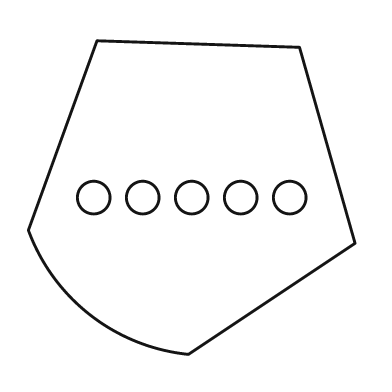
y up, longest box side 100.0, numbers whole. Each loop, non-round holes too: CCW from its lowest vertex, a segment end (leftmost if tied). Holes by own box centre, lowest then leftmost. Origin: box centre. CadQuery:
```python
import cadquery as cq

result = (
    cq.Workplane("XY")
    .moveTo(-1.0, -48.0)
    .lineTo(50.0, -14.0)
    .lineTo(33.0, 46.0)
    .lineTo(-29.0, 48.0)
    .lineTo(-50.0, -10.0)
    .threePointArc((-31.0, -36.0), (-1.0, -48.0))
    .close()
    .moveTo(-30.0, 0.0)
    .circle(5.0)
    .moveTo(-15.0, 0.0)
    .circle(5.0)
    .moveTo(0.0, 0.0)
    .circle(5.0)
    .moveTo(15.0, 0.0)
    .circle(5.0)
    .moveTo(30.0, 0.0)
    .circle(5.0)
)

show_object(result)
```